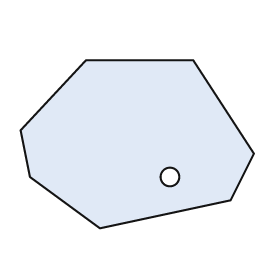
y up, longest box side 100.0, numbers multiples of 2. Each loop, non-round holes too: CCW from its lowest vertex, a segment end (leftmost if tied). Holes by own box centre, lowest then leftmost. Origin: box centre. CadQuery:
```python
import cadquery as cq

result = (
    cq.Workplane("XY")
    .moveTo(-16.0, -36.0)
    .lineTo(40.0, -24.0)
    .lineTo(50.0, -4.0)
    .lineTo(24.0, 36.0)
    .lineTo(-22.0, 36.0)
    .lineTo(-50.0, 6.0)
    .lineTo(-46.0, -14.0)
    .close()
    .moveTo(14.0, -14.0)
    .circle(4.0)
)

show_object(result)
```